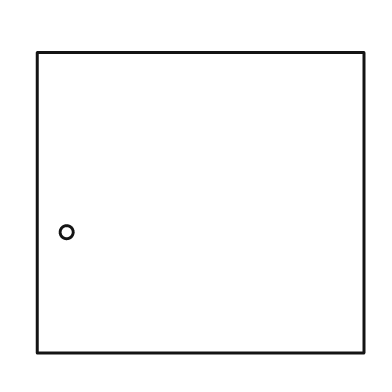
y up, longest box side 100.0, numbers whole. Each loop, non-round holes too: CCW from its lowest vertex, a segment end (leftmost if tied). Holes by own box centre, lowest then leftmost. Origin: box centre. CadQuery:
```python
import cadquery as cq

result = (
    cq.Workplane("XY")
    .moveTo(-50.0, -46.0)
    .lineTo(50.0, -46.0)
    .lineTo(50.0, 46.0)
    .lineTo(-50.0, 46.0)
    .close()
    .moveTo(-41.0, -9.0)
    .circle(2.0)
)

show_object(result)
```